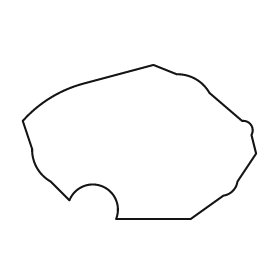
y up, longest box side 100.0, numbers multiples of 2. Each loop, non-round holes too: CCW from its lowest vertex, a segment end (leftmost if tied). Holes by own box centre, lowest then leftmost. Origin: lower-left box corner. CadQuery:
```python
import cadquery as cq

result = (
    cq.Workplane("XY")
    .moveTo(40.0, 0.0)
    .lineTo(72.0, 0.0)
    .lineTo(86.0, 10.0)
    .threePointArc((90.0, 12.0), (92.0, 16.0))
    .lineTo(100.0, 28.0)
    .lineTo(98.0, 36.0)
    .threePointArc((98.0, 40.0), (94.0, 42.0))
    .lineTo(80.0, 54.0)
    .threePointArc((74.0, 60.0), (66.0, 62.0))
    .lineTo(56.0, 66.0)
    .lineTo(26.0, 58.0)
    .threePointArc((12.0, 52.0), (0.0, 42.0))
    .lineTo(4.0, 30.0)
    .threePointArc((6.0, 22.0), (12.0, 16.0))
    .lineTo(20.0, 8.0)
    .threePointArc((34.0, 14.0), (40.0, 0.0))
    .close()
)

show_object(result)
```